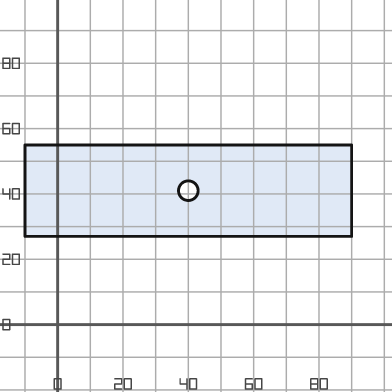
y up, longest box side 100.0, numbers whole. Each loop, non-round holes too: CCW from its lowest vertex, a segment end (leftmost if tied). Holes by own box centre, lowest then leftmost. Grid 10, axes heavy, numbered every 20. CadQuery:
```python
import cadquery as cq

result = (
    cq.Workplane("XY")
    .moveTo(-10.0, 27.0)
    .lineTo(90.0, 27.0)
    .lineTo(90.0, 55.0)
    .lineTo(-10.0, 55.0)
    .close()
    .moveTo(40.0, 41.0)
    .circle(3.0)
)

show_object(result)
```